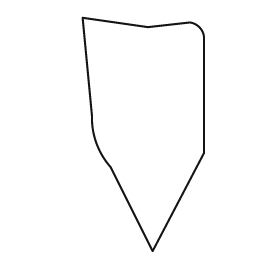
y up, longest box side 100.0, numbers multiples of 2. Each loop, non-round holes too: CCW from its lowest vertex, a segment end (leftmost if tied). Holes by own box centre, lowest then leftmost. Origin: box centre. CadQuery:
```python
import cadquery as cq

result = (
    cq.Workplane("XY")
    .moveTo(4.0, -50.0)
    .lineTo(26.0, -8.0)
    .lineTo(26.0, 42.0)
    .threePointArc((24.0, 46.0), (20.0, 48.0))
    .lineTo(2.0, 46.0)
    .lineTo(-26.0, 50.0)
    .lineTo(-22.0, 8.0)
    .threePointArc((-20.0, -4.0), (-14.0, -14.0))
    .close()
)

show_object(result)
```